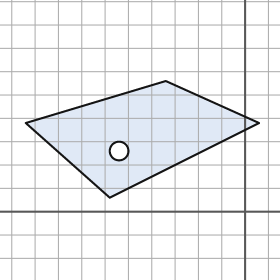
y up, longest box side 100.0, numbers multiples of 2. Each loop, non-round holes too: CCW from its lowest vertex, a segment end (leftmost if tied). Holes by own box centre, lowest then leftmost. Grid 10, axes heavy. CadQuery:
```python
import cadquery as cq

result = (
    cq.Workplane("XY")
    .moveTo(-58.0, 6.0)
    .lineTo(6.0, 38.0)
    .lineTo(-34.0, 56.0)
    .lineTo(-94.0, 38.0)
    .close()
    .moveTo(-54.0, 26.0)
    .circle(4.0)
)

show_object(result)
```